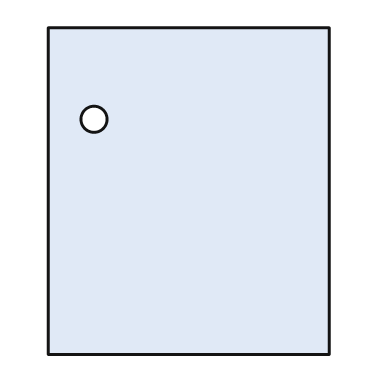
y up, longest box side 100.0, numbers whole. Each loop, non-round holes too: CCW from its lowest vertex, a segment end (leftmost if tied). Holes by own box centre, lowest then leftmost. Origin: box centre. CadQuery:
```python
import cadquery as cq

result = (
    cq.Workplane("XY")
    .moveTo(-43.0, -50.0)
    .lineTo(43.0, -50.0)
    .lineTo(43.0, 50.0)
    .lineTo(-43.0, 50.0)
    .close()
    .moveTo(-29.0, 22.0)
    .circle(4.0)
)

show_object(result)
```